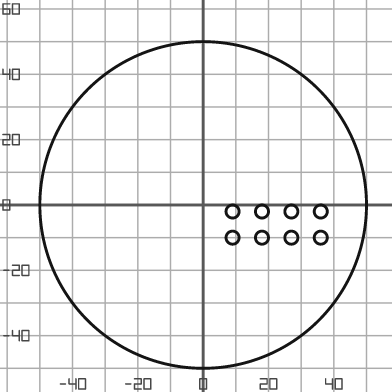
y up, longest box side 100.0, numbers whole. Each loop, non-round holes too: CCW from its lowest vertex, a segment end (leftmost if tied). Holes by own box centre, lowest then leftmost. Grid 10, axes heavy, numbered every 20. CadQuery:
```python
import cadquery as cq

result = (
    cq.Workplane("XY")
    .moveTo(0.0, 0.0)
    .circle(50.0)
    .moveTo(9.0, -10.0)
    .circle(2.0)
    .moveTo(18.0, -10.0)
    .circle(2.0)
    .moveTo(27.0, -10.0)
    .circle(2.0)
    .moveTo(36.0, -10.0)
    .circle(2.0)
    .moveTo(9.0, -2.0)
    .circle(2.0)
    .moveTo(18.0, -2.0)
    .circle(2.0)
    .moveTo(27.0, -2.0)
    .circle(2.0)
    .moveTo(36.0, -2.0)
    .circle(2.0)
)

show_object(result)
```